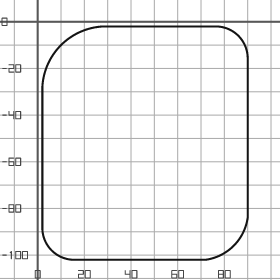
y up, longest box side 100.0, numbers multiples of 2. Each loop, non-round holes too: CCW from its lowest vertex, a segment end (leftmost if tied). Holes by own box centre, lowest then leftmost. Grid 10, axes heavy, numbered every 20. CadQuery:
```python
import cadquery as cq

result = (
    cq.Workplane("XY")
    .moveTo(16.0, -102.0)
    .lineTo(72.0, -102.0)
    .threePointArc((84.0, -96.0), (90.0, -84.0))
    .lineTo(90.0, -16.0)
    .threePointArc((86.0, -6.0), (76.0, -2.0))
    .lineTo(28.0, -2.0)
    .threePointArc((10.0, -10.0), (2.0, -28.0))
    .lineTo(2.0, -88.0)
    .threePointArc((6.0, -98.0), (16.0, -102.0))
    .close()
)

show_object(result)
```